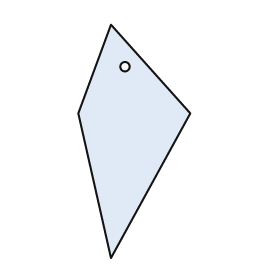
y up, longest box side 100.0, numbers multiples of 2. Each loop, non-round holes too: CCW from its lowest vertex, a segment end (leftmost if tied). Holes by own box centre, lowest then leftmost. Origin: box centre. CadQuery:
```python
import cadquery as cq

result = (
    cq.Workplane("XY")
    .moveTo(-10.0, -50.0)
    .lineTo(24.0, 12.0)
    .lineTo(-10.0, 50.0)
    .lineTo(-24.0, 12.0)
    .close()
    .moveTo(-4.0, 32.0)
    .circle(2.0)
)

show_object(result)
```